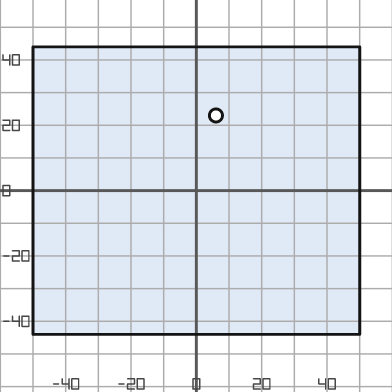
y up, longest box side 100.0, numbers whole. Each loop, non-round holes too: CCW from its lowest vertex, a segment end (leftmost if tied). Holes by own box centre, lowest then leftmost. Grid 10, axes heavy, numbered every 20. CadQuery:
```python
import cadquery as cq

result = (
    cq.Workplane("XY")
    .moveTo(-50.0, -44.0)
    .lineTo(50.0, -44.0)
    .lineTo(50.0, 44.0)
    .lineTo(-50.0, 44.0)
    .close()
    .moveTo(6.0, 23.0)
    .circle(2.0)
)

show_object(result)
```